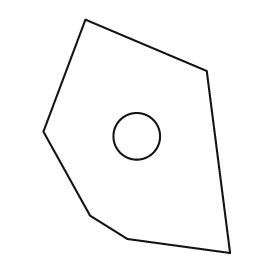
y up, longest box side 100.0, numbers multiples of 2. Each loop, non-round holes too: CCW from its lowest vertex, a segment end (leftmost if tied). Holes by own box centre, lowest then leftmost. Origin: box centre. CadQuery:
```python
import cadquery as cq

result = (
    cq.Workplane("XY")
    .moveTo(40.0, -50.0)
    .lineTo(30.0, 28.0)
    .lineTo(-22.0, 50.0)
    .lineTo(-40.0, 2.0)
    .lineTo(-20.0, -34.0)
    .lineTo(-4.0, -44.0)
    .close()
    .moveTo(0.0, 0.0)
    .circle(10.0)
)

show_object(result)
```